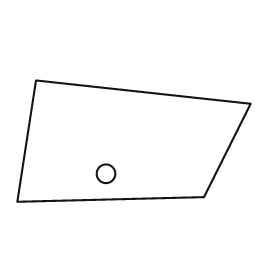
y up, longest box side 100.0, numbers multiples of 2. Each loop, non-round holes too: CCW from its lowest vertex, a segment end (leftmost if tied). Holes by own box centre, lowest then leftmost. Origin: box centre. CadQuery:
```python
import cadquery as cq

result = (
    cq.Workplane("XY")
    .moveTo(-50.0, -26.0)
    .lineTo(30.0, -24.0)
    .lineTo(50.0, 16.0)
    .lineTo(-42.0, 26.0)
    .close()
    .moveTo(-12.0, -14.0)
    .circle(4.0)
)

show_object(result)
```